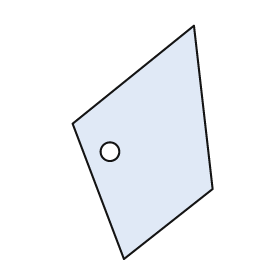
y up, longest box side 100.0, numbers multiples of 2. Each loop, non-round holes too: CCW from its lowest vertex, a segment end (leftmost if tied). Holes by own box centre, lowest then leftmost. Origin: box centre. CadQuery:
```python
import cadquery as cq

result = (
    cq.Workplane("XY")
    .moveTo(-8.0, -50.0)
    .lineTo(30.0, -20.0)
    .lineTo(22.0, 50.0)
    .lineTo(-30.0, 8.0)
    .close()
    .moveTo(-14.0, -4.0)
    .circle(4.0)
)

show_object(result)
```